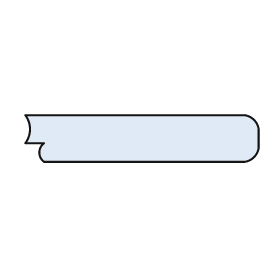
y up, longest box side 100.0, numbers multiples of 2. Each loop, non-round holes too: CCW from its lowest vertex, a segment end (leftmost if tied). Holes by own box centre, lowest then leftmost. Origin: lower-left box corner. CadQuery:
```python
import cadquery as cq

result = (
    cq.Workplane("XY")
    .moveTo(8.0, 0.0)
    .lineTo(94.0, 0.0)
    .threePointArc((98.0, 2.0), (100.0, 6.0))
    .lineTo(100.0, 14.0)
    .threePointArc((98.0, 18.0), (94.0, 20.0))
    .lineTo(0.0, 20.0)
    .threePointArc((2.0, 14.0), (0.0, 8.0))
    .lineTo(8.0, 8.0)
    .threePointArc((6.0, 4.0), (8.0, 0.0))
    .close()
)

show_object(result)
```